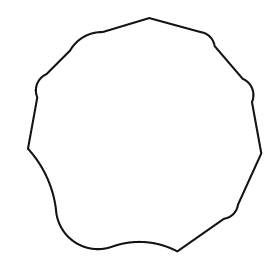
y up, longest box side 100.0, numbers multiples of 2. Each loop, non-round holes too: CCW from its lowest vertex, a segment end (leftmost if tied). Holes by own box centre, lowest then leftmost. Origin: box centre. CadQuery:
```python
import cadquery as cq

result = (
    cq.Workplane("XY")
    .moveTo(14.0, -50.0)
    .lineTo(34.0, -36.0)
    .threePointArc((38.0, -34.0), (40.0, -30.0))
    .lineTo(50.0, -8.0)
    .lineTo(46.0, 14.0)
    .threePointArc((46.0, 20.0), (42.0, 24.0))
    .lineTo(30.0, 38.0)
    .threePointArc((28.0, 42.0), (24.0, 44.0))
    .lineTo(2.0, 50.0)
    .lineTo(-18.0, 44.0)
    .threePointArc((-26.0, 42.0), (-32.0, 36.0))
    .lineTo(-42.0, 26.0)
    .threePointArc((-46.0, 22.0), (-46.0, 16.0))
    .lineTo(-50.0, -6.0)
    .threePointArc((-42.0, -18.0), (-38.0, -32.0))
    .threePointArc((-30.0, -46.0), (-14.0, -48.0))
    .threePointArc((0.0, -46.0), (14.0, -50.0))
    .close()
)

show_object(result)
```